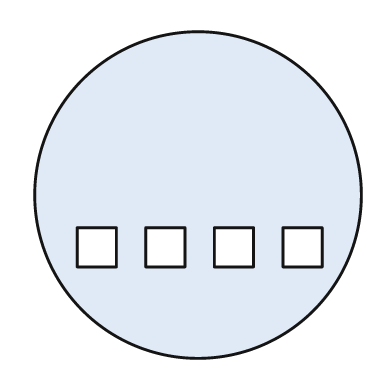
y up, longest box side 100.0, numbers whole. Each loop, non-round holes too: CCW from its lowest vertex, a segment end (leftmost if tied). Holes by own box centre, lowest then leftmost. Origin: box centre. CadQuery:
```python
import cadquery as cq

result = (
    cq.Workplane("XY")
    .moveTo(0.0, 0.0)
    .circle(50.0)
    .moveTo(-37.0, -22.0)
    .lineTo(-25.0, -22.0)
    .lineTo(-25.0, -10.0)
    .lineTo(-37.0, -10.0)
    .close()
    .moveTo(-16.0, -22.0)
    .lineTo(-4.0, -22.0)
    .lineTo(-4.0, -10.0)
    .lineTo(-16.0, -10.0)
    .close()
    .moveTo(5.0, -22.0)
    .lineTo(17.0, -22.0)
    .lineTo(17.0, -10.0)
    .lineTo(5.0, -10.0)
    .close()
    .moveTo(26.0, -22.0)
    .lineTo(38.0, -22.0)
    .lineTo(38.0, -10.0)
    .lineTo(26.0, -10.0)
    .close()
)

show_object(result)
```